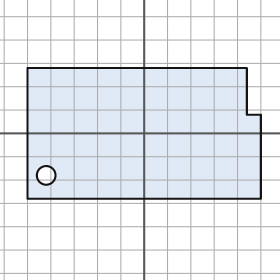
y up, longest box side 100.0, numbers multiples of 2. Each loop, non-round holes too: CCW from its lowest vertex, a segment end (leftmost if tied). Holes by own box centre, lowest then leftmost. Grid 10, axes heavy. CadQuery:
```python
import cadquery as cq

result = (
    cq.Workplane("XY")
    .moveTo(-50.0, -28.0)
    .lineTo(50.0, -28.0)
    .lineTo(50.0, 8.0)
    .lineTo(44.0, 8.0)
    .lineTo(44.0, 28.0)
    .lineTo(-50.0, 28.0)
    .close()
    .moveTo(-42.0, -18.0)
    .circle(4.0)
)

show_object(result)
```